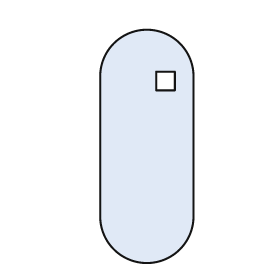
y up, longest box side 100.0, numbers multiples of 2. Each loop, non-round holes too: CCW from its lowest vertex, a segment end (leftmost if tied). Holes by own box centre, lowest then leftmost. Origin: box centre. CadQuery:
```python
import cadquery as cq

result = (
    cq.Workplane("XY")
    .moveTo(-20.0, -30.0)
    .threePointArc((0.0, -50.0), (20.0, -30.0))
    .lineTo(20.0, 30.0)
    .threePointArc((0.0, 50.0), (-20.0, 30.0))
    .close()
    .moveTo(4.0, 24.0)
    .lineTo(12.0, 24.0)
    .lineTo(12.0, 32.0)
    .lineTo(4.0, 32.0)
    .close()
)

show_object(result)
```